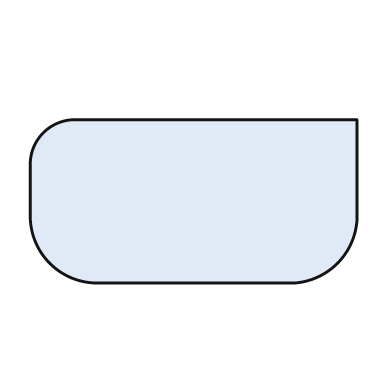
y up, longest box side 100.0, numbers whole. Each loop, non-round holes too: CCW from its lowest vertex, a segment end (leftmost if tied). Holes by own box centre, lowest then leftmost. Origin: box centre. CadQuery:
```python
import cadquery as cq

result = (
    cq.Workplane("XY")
    .moveTo(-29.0, -25.0)
    .lineTo(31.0, -25.0)
    .threePointArc((44.0, -19.0), (50.0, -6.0))
    .lineTo(50.0, 25.0)
    .lineTo(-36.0, 25.0)
    .threePointArc((-46.0, 21.0), (-50.0, 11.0))
    .lineTo(-50.0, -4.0)
    .threePointArc((-44.0, -19.0), (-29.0, -25.0))
    .close()
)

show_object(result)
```